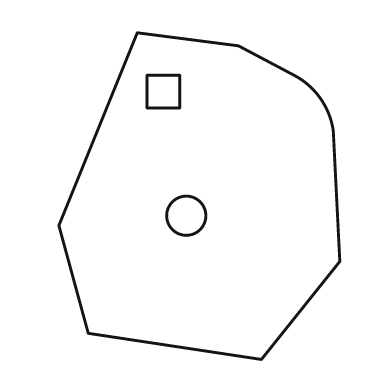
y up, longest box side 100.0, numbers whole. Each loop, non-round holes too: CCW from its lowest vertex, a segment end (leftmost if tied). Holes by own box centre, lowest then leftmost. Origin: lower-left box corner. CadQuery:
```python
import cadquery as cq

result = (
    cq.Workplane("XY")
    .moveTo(62.0, 0.0)
    .lineTo(86.0, 30.0)
    .lineTo(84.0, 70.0)
    .threePointArc((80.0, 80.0), (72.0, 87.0))
    .lineTo(55.0, 96.0)
    .lineTo(24.0, 100.0)
    .lineTo(0.0, 41.0)
    .lineTo(9.0, 8.0)
    .close()
    .moveTo(39.0, 44.0)
    .circle(6.0)
    .moveTo(27.0, 77.0)
    .lineTo(37.0, 77.0)
    .lineTo(37.0, 87.0)
    .lineTo(27.0, 87.0)
    .close()
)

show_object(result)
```